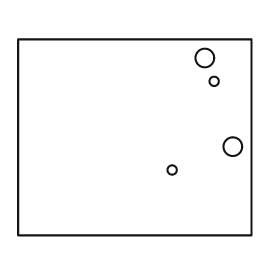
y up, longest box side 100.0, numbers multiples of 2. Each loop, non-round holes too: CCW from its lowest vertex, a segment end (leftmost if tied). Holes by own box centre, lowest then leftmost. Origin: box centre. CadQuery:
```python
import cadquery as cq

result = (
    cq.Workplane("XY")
    .moveTo(-50.0, -42.0)
    .lineTo(50.0, -42.0)
    .lineTo(50.0, 42.0)
    .lineTo(-50.0, 42.0)
    .close()
    .moveTo(16.0, -14.0)
    .circle(2.0)
    .moveTo(42.0, -4.0)
    .circle(4.0)
    .moveTo(34.0, 24.0)
    .circle(2.0)
    .moveTo(30.0, 34.0)
    .circle(4.0)
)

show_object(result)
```